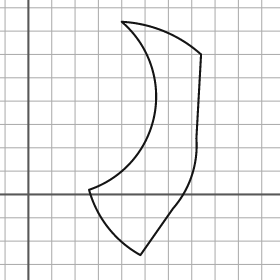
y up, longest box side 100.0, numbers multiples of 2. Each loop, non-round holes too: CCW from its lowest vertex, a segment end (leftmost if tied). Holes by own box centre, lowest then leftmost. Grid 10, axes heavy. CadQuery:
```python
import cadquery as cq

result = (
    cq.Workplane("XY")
    .moveTo(48.0, -26.0)
    .lineTo(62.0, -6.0)
    .threePointArc((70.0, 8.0), (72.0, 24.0))
    .lineTo(74.0, 60.0)
    .threePointArc((58.0, 70.0), (40.0, 74.0))
    .threePointArc((54.0, 34.0), (26.0, 2.0))
    .threePointArc((34.0, -14.0), (48.0, -26.0))
    .close()
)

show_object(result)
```